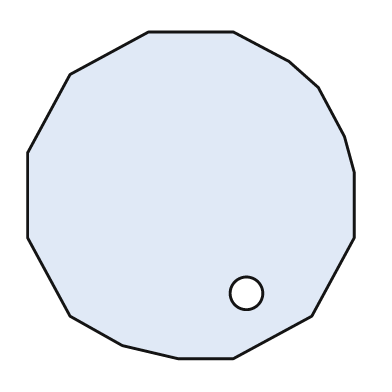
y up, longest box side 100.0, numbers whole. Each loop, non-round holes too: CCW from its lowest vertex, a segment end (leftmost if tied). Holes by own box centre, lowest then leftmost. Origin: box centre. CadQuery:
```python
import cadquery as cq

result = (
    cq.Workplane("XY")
    .moveTo(-4.0, -50.0)
    .lineTo(13.0, -50.0)
    .lineTo(37.0, -37.0)
    .lineTo(50.0, -13.0)
    .lineTo(50.0, 7.0)
    .lineTo(47.0, 18.0)
    .lineTo(39.0, 33.0)
    .lineTo(30.0, 41.0)
    .lineTo(13.0, 50.0)
    .lineTo(-13.0, 50.0)
    .lineTo(-37.0, 37.0)
    .lineTo(-50.0, 13.0)
    .lineTo(-50.0, -13.0)
    .lineTo(-37.0, -37.0)
    .lineTo(-21.0, -46.0)
    .close()
    .moveTo(17.0, -30.0)
    .circle(5.0)
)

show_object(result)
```